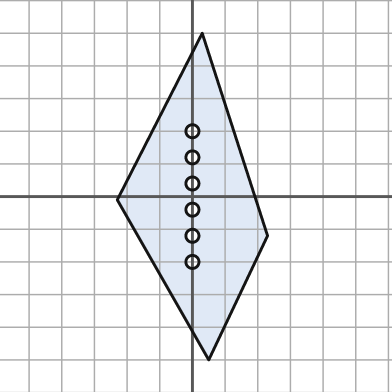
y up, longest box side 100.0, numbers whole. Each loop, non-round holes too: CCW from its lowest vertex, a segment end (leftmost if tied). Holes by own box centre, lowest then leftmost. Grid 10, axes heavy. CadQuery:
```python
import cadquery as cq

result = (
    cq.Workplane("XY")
    .moveTo(5.0, -50.0)
    .lineTo(23.0, -12.0)
    .lineTo(3.0, 50.0)
    .lineTo(-23.0, -1.0)
    .close()
    .moveTo(0.0, -20.0)
    .circle(2.0)
    .moveTo(0.0, -12.0)
    .circle(2.0)
    .moveTo(0.0, -4.0)
    .circle(2.0)
    .moveTo(0.0, 4.0)
    .circle(2.0)
    .moveTo(0.0, 12.0)
    .circle(2.0)
    .moveTo(0.0, 20.0)
    .circle(2.0)
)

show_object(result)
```